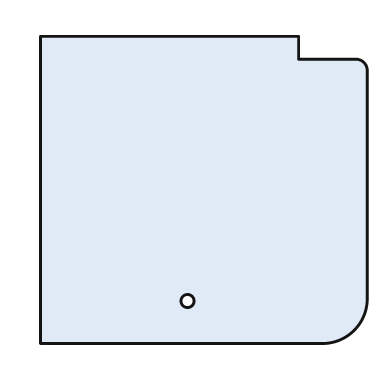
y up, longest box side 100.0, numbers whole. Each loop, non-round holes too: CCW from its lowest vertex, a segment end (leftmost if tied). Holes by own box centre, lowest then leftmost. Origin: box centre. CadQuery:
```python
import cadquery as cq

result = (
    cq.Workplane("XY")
    .moveTo(-50.0, -47.0)
    .lineTo(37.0, -47.0)
    .threePointArc((46.0, -43.0), (50.0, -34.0))
    .lineTo(50.0, 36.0)
    .threePointArc((49.0, 39.0), (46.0, 40.0))
    .lineTo(29.0, 40.0)
    .lineTo(29.0, 47.0)
    .lineTo(-50.0, 47.0)
    .close()
    .moveTo(-5.0, -34.0)
    .circle(2.0)
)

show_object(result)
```